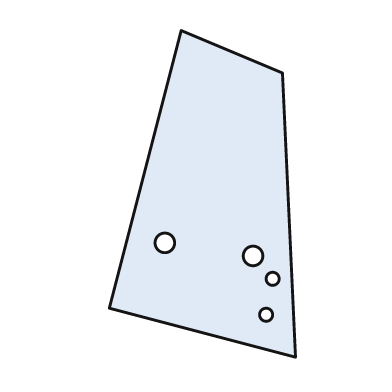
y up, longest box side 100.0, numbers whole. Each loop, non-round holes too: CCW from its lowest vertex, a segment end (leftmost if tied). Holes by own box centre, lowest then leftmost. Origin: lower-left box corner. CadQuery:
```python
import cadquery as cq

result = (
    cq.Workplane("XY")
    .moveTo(57.0, 0.0)
    .lineTo(53.0, 87.0)
    .lineTo(22.0, 100.0)
    .lineTo(0.0, 15.0)
    .close()
    .moveTo(48.0, 13.0)
    .circle(2.0)
    .moveTo(50.0, 24.0)
    .circle(2.0)
    .moveTo(44.0, 31.0)
    .circle(3.0)
    .moveTo(17.0, 35.0)
    .circle(3.0)
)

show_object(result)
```